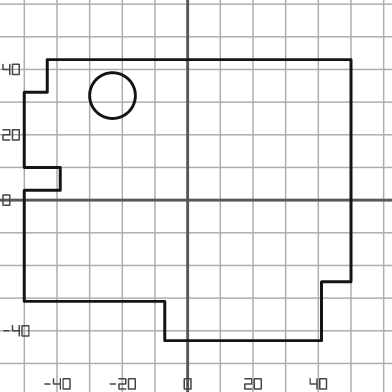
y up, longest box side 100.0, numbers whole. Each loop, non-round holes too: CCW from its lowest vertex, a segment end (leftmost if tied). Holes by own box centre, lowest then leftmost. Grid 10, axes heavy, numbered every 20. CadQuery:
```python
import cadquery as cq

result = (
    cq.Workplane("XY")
    .moveTo(-7.0, -43.0)
    .lineTo(41.0, -43.0)
    .lineTo(41.0, -25.0)
    .lineTo(50.0, -25.0)
    .lineTo(50.0, 43.0)
    .lineTo(-43.0, 43.0)
    .lineTo(-43.0, 33.0)
    .lineTo(-50.0, 33.0)
    .lineTo(-50.0, 10.0)
    .lineTo(-39.0, 10.0)
    .lineTo(-39.0, 3.0)
    .lineTo(-50.0, 3.0)
    .lineTo(-50.0, -31.0)
    .lineTo(-7.0, -31.0)
    .close()
    .moveTo(-23.0, 32.0)
    .circle(7.0)
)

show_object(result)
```